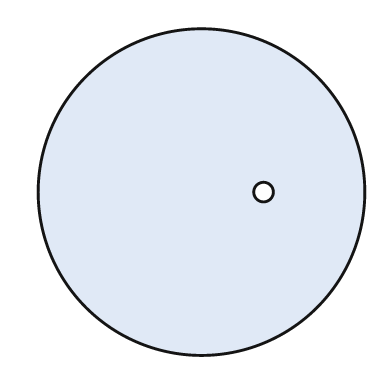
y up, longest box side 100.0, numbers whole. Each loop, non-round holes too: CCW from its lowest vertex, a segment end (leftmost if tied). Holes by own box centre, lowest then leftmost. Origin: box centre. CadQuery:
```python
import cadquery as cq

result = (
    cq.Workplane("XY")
    .moveTo(0.0, 0.0)
    .circle(50.0)
    .moveTo(19.0, 0.0)
    .circle(3.0)
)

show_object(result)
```